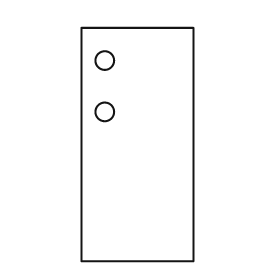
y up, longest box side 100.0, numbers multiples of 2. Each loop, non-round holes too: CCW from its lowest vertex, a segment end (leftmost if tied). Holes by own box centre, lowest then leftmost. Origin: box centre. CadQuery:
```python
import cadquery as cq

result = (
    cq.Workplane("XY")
    .moveTo(-24.0, -50.0)
    .lineTo(24.0, -50.0)
    .lineTo(24.0, 50.0)
    .lineTo(-24.0, 50.0)
    .close()
    .moveTo(-14.0, 14.0)
    .circle(4.0)
    .moveTo(-14.0, 36.0)
    .circle(4.0)
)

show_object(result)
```